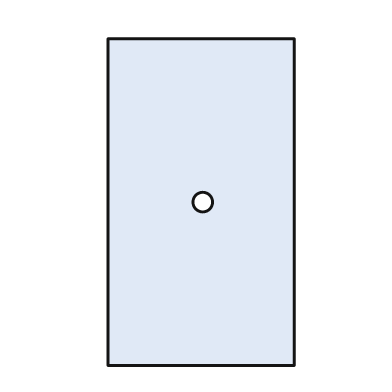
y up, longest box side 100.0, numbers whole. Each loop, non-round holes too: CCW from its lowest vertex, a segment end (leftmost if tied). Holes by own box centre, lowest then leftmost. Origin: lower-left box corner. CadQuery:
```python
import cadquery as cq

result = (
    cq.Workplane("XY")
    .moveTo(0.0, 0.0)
    .lineTo(57.0, 0.0)
    .lineTo(57.0, 100.0)
    .lineTo(0.0, 100.0)
    .close()
    .moveTo(29.0, 50.0)
    .circle(3.0)
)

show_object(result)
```